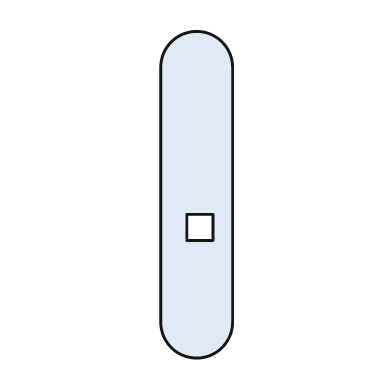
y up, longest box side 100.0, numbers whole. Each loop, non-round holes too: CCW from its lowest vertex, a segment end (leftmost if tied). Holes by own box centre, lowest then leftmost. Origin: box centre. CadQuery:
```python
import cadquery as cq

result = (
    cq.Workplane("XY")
    .moveTo(-11.0, -39.0)
    .threePointArc((0.0, -50.0), (11.0, -39.0))
    .lineTo(11.0, 39.0)
    .threePointArc((0.0, 50.0), (-11.0, 39.0))
    .close()
    .moveTo(-3.0, -14.0)
    .lineTo(5.0, -14.0)
    .lineTo(5.0, -6.0)
    .lineTo(-3.0, -6.0)
    .close()
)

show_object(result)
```